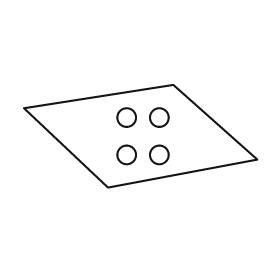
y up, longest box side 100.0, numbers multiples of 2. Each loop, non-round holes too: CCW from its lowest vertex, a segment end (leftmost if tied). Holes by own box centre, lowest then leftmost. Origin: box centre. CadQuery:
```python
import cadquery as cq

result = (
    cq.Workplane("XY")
    .moveTo(-14.0, -22.0)
    .lineTo(50.0, -10.0)
    .lineTo(14.0, 22.0)
    .lineTo(-50.0, 12.0)
    .close()
    .moveTo(-6.0, -8.0)
    .circle(4.0)
    .moveTo(8.0, -8.0)
    .circle(4.0)
    .moveTo(-6.0, 8.0)
    .circle(4.0)
    .moveTo(8.0, 8.0)
    .circle(4.0)
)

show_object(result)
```